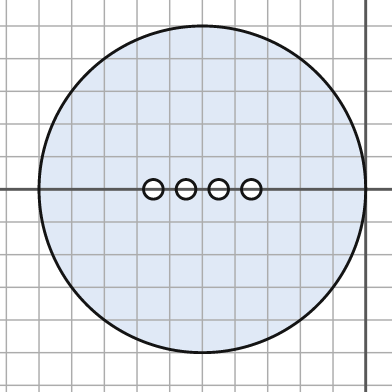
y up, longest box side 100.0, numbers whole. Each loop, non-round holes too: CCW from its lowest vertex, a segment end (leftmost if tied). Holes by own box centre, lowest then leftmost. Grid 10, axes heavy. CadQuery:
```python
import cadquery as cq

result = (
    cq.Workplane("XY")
    .moveTo(-50.0, 0.0)
    .circle(50.0)
    .moveTo(-65.0, 0.0)
    .circle(3.0)
    .moveTo(-55.0, 0.0)
    .circle(3.0)
    .moveTo(-45.0, 0.0)
    .circle(3.0)
    .moveTo(-35.0, 0.0)
    .circle(3.0)
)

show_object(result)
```